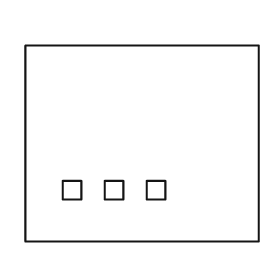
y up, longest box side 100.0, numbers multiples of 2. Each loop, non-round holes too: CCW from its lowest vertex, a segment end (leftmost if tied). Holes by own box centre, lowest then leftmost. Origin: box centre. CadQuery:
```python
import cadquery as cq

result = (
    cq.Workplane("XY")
    .moveTo(-50.0, -42.0)
    .lineTo(50.0, -42.0)
    .lineTo(50.0, 42.0)
    .lineTo(-50.0, 42.0)
    .close()
    .moveTo(-34.0, -24.0)
    .lineTo(-26.0, -24.0)
    .lineTo(-26.0, -16.0)
    .lineTo(-34.0, -16.0)
    .close()
    .moveTo(-16.0, -24.0)
    .lineTo(-8.0, -24.0)
    .lineTo(-8.0, -16.0)
    .lineTo(-16.0, -16.0)
    .close()
    .moveTo(2.0, -24.0)
    .lineTo(10.0, -24.0)
    .lineTo(10.0, -16.0)
    .lineTo(2.0, -16.0)
    .close()
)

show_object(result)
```